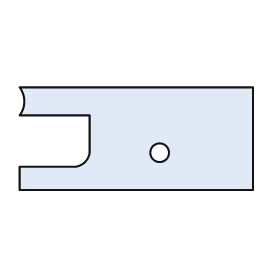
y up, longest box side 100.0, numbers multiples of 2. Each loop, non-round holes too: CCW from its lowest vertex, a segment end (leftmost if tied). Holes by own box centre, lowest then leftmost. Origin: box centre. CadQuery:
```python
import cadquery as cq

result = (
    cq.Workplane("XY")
    .moveTo(-50.0, -22.0)
    .lineTo(50.0, -22.0)
    .lineTo(50.0, 22.0)
    .lineTo(-50.0, 22.0)
    .threePointArc((-48.0, 16.0), (-50.0, 10.0))
    .lineTo(-20.0, 10.0)
    .lineTo(-20.0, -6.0)
    .threePointArc((-22.0, -10.0), (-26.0, -12.0))
    .lineTo(-50.0, -12.0)
    .close()
    .moveTo(10.0, -6.0)
    .circle(4.0)
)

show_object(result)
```